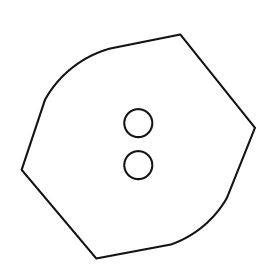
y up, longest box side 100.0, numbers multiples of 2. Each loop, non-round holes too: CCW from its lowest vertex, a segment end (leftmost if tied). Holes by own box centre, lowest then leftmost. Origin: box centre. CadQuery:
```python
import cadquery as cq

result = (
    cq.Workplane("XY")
    .moveTo(-18.0, -48.0)
    .lineTo(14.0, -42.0)
    .threePointArc((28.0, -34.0), (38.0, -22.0))
    .lineTo(50.0, 8.0)
    .lineTo(18.0, 48.0)
    .lineTo(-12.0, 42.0)
    .threePointArc((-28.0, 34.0), (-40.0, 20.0))
    .lineTo(-50.0, -10.0)
    .close()
    .moveTo(0.0, -8.0)
    .circle(6.0)
    .moveTo(0.0, 10.0)
    .circle(6.0)
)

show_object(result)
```